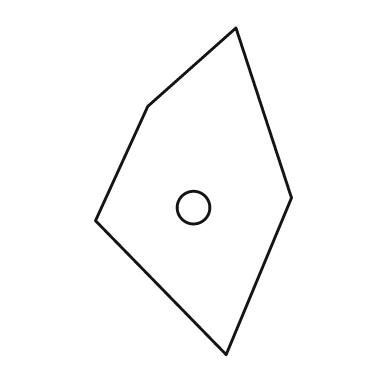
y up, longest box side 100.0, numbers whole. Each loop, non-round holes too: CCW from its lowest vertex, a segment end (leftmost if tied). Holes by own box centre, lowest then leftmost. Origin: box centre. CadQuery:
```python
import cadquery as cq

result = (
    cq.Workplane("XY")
    .moveTo(10.0, -50.0)
    .lineTo(30.0, -2.0)
    .lineTo(13.0, 50.0)
    .lineTo(-14.0, 26.0)
    .lineTo(-30.0, -9.0)
    .close()
    .moveTo(0.0, -5.0)
    .circle(5.0)
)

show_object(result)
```